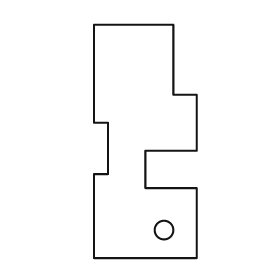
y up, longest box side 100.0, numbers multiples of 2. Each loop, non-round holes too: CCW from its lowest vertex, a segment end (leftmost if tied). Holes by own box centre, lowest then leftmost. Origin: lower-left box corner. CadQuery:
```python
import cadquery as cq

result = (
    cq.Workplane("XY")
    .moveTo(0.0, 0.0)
    .lineTo(44.0, 0.0)
    .lineTo(44.0, 30.0)
    .lineTo(22.0, 30.0)
    .lineTo(22.0, 46.0)
    .lineTo(44.0, 46.0)
    .lineTo(44.0, 70.0)
    .lineTo(34.0, 70.0)
    .lineTo(34.0, 100.0)
    .lineTo(0.0, 100.0)
    .lineTo(0.0, 58.0)
    .lineTo(6.0, 58.0)
    .lineTo(6.0, 36.0)
    .lineTo(0.0, 36.0)
    .close()
    .moveTo(30.0, 12.0)
    .circle(4.0)
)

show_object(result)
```